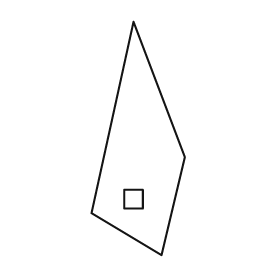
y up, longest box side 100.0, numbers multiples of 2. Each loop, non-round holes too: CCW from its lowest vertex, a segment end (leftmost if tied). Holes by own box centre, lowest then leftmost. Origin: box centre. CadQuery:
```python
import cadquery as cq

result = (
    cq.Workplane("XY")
    .moveTo(10.0, -50.0)
    .lineTo(20.0, -8.0)
    .lineTo(-2.0, 50.0)
    .lineTo(-20.0, -32.0)
    .close()
    .moveTo(-6.0, -30.0)
    .lineTo(2.0, -30.0)
    .lineTo(2.0, -22.0)
    .lineTo(-6.0, -22.0)
    .close()
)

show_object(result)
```